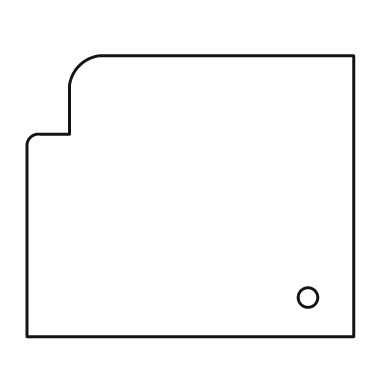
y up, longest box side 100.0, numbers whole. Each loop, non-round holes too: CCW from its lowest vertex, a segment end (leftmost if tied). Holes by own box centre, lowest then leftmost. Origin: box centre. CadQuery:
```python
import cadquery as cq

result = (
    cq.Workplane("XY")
    .moveTo(-50.0, -43.0)
    .lineTo(50.0, -43.0)
    .lineTo(50.0, 43.0)
    .lineTo(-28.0, 43.0)
    .threePointArc((-34.0, 40.0), (-37.0, 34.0))
    .lineTo(-37.0, 19.0)
    .lineTo(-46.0, 19.0)
    .threePointArc((-49.0, 18.0), (-50.0, 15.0))
    .close()
    .moveTo(36.0, -31.0)
    .circle(3.0)
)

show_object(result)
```